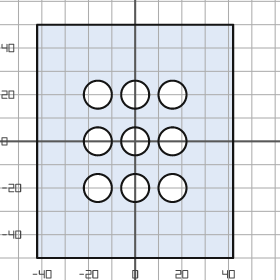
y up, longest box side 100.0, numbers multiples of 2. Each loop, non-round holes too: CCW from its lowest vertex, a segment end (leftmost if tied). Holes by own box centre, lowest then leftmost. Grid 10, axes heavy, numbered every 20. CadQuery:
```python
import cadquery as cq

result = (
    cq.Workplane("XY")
    .moveTo(-42.0, -50.0)
    .lineTo(42.0, -50.0)
    .lineTo(42.0, 50.0)
    .lineTo(-42.0, 50.0)
    .close()
    .moveTo(-16.0, -20.0)
    .circle(6.0)
    .moveTo(0.0, -20.0)
    .circle(6.0)
    .moveTo(16.0, -20.0)
    .circle(6.0)
    .moveTo(-16.0, 0.0)
    .circle(6.0)
    .moveTo(0.0, 0.0)
    .circle(6.0)
    .moveTo(16.0, 0.0)
    .circle(6.0)
    .moveTo(-16.0, 20.0)
    .circle(6.0)
    .moveTo(0.0, 20.0)
    .circle(6.0)
    .moveTo(16.0, 20.0)
    .circle(6.0)
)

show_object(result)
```